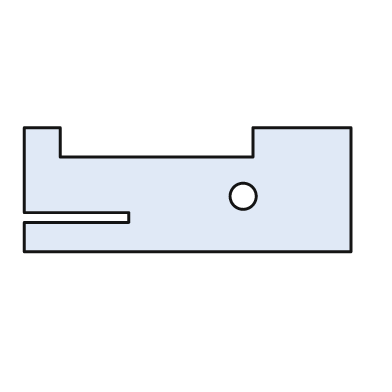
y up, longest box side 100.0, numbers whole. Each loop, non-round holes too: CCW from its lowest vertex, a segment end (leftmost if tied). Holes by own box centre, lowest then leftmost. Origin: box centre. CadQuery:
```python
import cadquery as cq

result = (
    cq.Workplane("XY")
    .moveTo(-50.0, -19.0)
    .lineTo(50.0, -19.0)
    .lineTo(50.0, 19.0)
    .lineTo(20.0, 19.0)
    .lineTo(20.0, 10.0)
    .lineTo(-39.0, 10.0)
    .lineTo(-39.0, 19.0)
    .lineTo(-50.0, 19.0)
    .lineTo(-50.0, -7.0)
    .lineTo(-18.0, -7.0)
    .lineTo(-18.0, -10.0)
    .lineTo(-50.0, -10.0)
    .close()
    .moveTo(17.0, -2.0)
    .circle(4.0)
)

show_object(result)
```